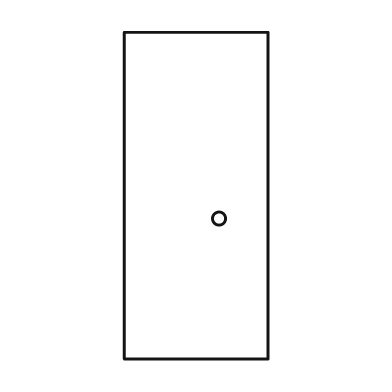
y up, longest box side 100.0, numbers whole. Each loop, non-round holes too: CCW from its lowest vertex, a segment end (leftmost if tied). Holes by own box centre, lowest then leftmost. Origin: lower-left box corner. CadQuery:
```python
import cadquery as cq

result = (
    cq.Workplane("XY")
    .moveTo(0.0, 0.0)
    .lineTo(44.0, 0.0)
    .lineTo(44.0, 100.0)
    .lineTo(0.0, 100.0)
    .close()
    .moveTo(29.0, 43.0)
    .circle(2.0)
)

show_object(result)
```